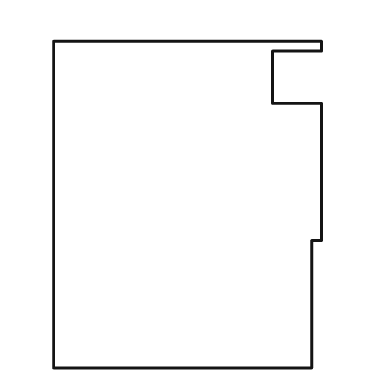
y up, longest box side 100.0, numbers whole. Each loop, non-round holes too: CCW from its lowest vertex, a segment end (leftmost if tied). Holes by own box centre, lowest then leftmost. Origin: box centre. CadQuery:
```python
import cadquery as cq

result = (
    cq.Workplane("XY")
    .moveTo(-41.0, -50.0)
    .lineTo(38.0, -50.0)
    .lineTo(38.0, -11.0)
    .lineTo(41.0, -11.0)
    .lineTo(41.0, 31.0)
    .lineTo(26.0, 31.0)
    .lineTo(26.0, 47.0)
    .lineTo(41.0, 47.0)
    .lineTo(41.0, 50.0)
    .lineTo(-41.0, 50.0)
    .close()
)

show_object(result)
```